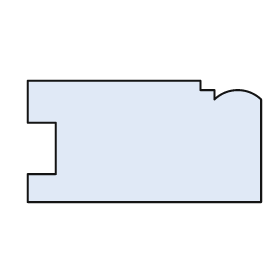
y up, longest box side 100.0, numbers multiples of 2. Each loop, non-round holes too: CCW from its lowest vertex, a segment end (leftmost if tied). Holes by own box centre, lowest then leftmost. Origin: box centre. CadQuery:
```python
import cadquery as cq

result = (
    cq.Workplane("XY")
    .moveTo(-50.0, -26.0)
    .lineTo(50.0, -26.0)
    .lineTo(50.0, 18.0)
    .threePointArc((40.0, 22.0), (30.0, 18.0))
    .lineTo(30.0, 22.0)
    .lineTo(24.0, 22.0)
    .lineTo(24.0, 26.0)
    .lineTo(-50.0, 26.0)
    .lineTo(-50.0, 8.0)
    .lineTo(-38.0, 8.0)
    .lineTo(-38.0, -14.0)
    .lineTo(-50.0, -14.0)
    .close()
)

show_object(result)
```